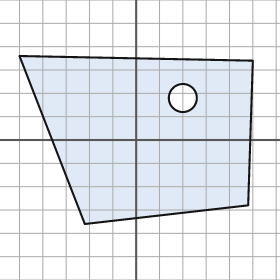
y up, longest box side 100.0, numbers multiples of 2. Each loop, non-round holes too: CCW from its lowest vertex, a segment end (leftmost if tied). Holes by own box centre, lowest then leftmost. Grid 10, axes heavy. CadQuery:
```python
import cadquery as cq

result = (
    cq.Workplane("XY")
    .moveTo(-22.0, -36.0)
    .lineTo(48.0, -28.0)
    .lineTo(50.0, 34.0)
    .lineTo(-50.0, 36.0)
    .close()
    .moveTo(20.0, 18.0)
    .circle(6.0)
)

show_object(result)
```